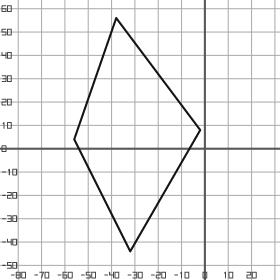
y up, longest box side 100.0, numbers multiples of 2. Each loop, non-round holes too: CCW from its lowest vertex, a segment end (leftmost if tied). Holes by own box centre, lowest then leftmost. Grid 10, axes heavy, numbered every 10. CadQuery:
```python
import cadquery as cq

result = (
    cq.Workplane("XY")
    .moveTo(-32.0, -44.0)
    .lineTo(-2.0, 8.0)
    .lineTo(-38.0, 56.0)
    .lineTo(-56.0, 4.0)
    .close()
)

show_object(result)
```